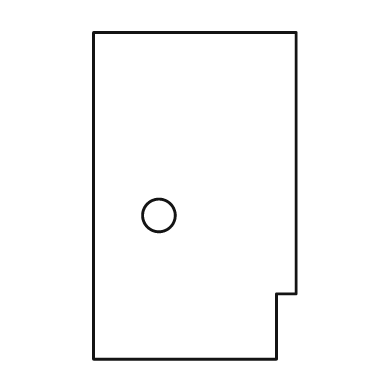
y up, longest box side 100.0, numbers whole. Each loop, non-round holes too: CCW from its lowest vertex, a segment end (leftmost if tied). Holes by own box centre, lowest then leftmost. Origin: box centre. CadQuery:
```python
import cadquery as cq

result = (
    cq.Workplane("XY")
    .moveTo(-31.0, -50.0)
    .lineTo(25.0, -50.0)
    .lineTo(25.0, -30.0)
    .lineTo(31.0, -30.0)
    .lineTo(31.0, 50.0)
    .lineTo(-31.0, 50.0)
    .close()
    .moveTo(-11.0, -6.0)
    .circle(5.0)
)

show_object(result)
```